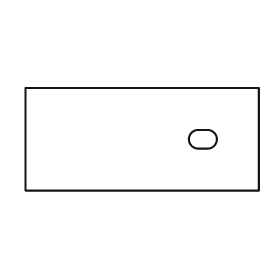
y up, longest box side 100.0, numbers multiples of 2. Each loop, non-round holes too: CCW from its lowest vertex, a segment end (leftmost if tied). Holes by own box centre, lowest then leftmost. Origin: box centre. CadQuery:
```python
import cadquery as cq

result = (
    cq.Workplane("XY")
    .moveTo(-50.0, -22.0)
    .lineTo(50.0, -22.0)
    .lineTo(50.0, 22.0)
    .lineTo(-50.0, 22.0)
    .close()
    .moveTo(24.0, -4.0)
    .lineTo(28.0, -4.0)
    .threePointArc((32.0, 0.0), (28.0, 4.0))
    .lineTo(24.0, 4.0)
    .threePointArc((20.0, 0.0), (24.0, -4.0))
    .close()
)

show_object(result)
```